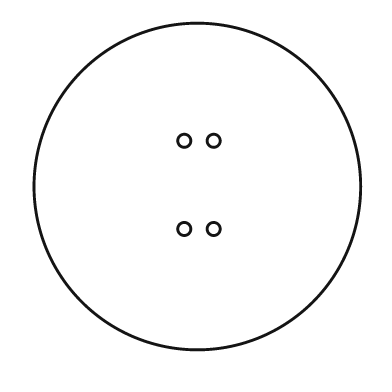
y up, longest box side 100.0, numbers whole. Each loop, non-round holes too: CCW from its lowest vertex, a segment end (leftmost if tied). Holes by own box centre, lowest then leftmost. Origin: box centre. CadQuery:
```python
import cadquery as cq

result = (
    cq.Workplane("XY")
    .moveTo(0.0, 0.0)
    .circle(50.0)
    .moveTo(-4.0, -13.0)
    .circle(2.0)
    .moveTo(5.0, -13.0)
    .circle(2.0)
    .moveTo(-4.0, 14.0)
    .circle(2.0)
    .moveTo(5.0, 14.0)
    .circle(2.0)
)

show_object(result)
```